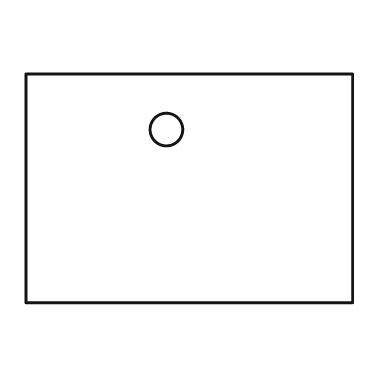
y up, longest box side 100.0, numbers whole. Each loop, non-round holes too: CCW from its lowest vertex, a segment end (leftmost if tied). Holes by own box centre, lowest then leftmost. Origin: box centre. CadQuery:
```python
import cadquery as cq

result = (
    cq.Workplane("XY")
    .moveTo(-50.0, -35.0)
    .lineTo(50.0, -35.0)
    .lineTo(50.0, 35.0)
    .lineTo(-50.0, 35.0)
    .close()
    .moveTo(-7.0, 18.0)
    .circle(5.0)
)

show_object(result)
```